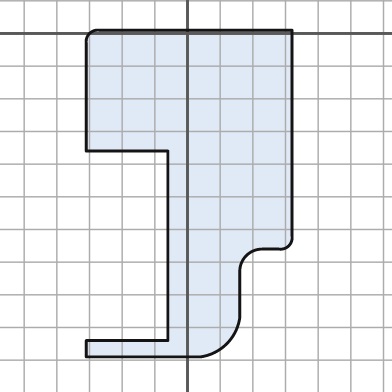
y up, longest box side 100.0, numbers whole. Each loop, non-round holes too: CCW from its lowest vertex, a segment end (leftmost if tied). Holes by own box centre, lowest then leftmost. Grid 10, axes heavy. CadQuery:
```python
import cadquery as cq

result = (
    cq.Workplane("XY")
    .moveTo(-31.0, -99.0)
    .lineTo(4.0, -99.0)
    .threePointArc((12.0, -95.0), (16.0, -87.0))
    .lineTo(16.0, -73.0)
    .threePointArc((18.0, -68.0), (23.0, -66.0))
    .lineTo(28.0, -66.0)
    .threePointArc((31.0, -65.0), (32.0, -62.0))
    .lineTo(32.0, 1.0)
    .lineTo(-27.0, 1.0)
    .threePointArc((-30.0, 0.0), (-31.0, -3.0))
    .lineTo(-31.0, -36.0)
    .lineTo(-6.0, -36.0)
    .lineTo(-6.0, -94.0)
    .lineTo(-31.0, -94.0)
    .close()
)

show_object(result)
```